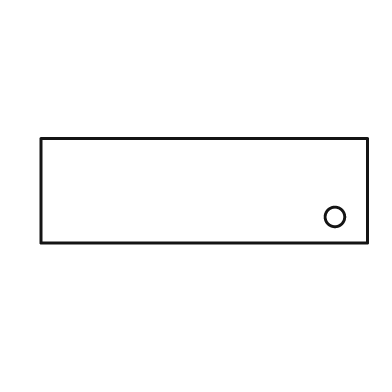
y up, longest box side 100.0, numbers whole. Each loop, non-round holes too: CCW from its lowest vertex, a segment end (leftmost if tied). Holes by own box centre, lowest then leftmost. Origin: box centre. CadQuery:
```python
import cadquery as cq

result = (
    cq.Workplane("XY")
    .moveTo(-50.0, -16.0)
    .lineTo(50.0, -16.0)
    .lineTo(50.0, 16.0)
    .lineTo(-50.0, 16.0)
    .close()
    .moveTo(40.0, -8.0)
    .circle(3.0)
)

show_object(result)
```